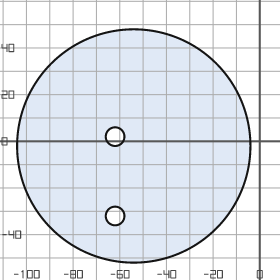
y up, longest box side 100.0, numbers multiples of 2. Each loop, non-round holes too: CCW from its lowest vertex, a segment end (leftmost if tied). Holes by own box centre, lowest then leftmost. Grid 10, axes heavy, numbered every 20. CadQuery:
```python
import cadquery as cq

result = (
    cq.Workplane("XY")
    .moveTo(-54.0, -2.0)
    .circle(50.0)
    .moveTo(-62.0, -32.0)
    .circle(4.0)
    .moveTo(-62.0, 2.0)
    .circle(4.0)
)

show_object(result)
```